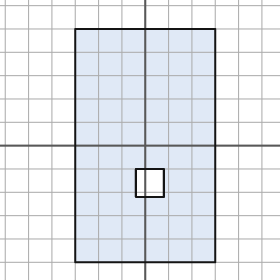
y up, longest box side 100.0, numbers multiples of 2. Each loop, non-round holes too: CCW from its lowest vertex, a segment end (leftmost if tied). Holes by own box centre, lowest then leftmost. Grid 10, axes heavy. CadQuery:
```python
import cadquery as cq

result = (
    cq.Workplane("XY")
    .moveTo(-30.0, -50.0)
    .lineTo(30.0, -50.0)
    .lineTo(30.0, 50.0)
    .lineTo(-30.0, 50.0)
    .close()
    .moveTo(-4.0, -22.0)
    .lineTo(8.0, -22.0)
    .lineTo(8.0, -10.0)
    .lineTo(-4.0, -10.0)
    .close()
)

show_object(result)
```